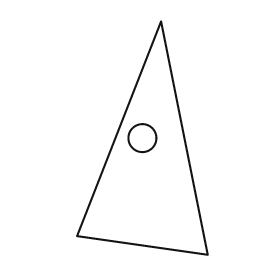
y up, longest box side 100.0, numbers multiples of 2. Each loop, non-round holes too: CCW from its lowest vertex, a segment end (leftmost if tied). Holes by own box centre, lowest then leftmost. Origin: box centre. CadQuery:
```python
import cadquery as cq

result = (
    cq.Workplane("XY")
    .moveTo(28.0, -50.0)
    .lineTo(8.0, 50.0)
    .lineTo(-28.0, -42.0)
    .close()
    .moveTo(0.0, 0.0)
    .circle(6.0)
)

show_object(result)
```